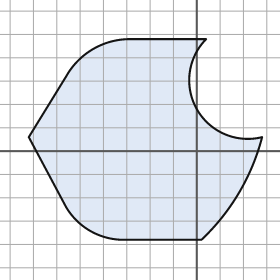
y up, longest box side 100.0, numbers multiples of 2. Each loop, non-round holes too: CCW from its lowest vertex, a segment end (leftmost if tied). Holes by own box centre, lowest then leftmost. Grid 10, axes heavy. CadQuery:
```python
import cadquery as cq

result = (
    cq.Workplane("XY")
    .moveTo(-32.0, -38.0)
    .lineTo(2.0, -38.0)
    .threePointArc((18.0, -18.0), (28.0, 6.0))
    .threePointArc((0.0, 18.0), (4.0, 48.0))
    .lineTo(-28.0, 48.0)
    .threePointArc((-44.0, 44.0), (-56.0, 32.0))
    .lineTo(-72.0, 6.0)
    .lineTo(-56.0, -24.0)
    .threePointArc((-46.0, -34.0), (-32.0, -38.0))
    .close()
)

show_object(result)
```